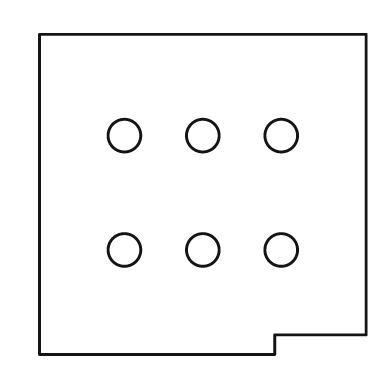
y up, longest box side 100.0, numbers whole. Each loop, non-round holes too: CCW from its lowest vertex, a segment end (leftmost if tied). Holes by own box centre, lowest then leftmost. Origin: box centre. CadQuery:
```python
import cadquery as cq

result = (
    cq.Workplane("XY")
    .moveTo(-50.0, -49.0)
    .lineTo(22.0, -49.0)
    .lineTo(22.0, -43.0)
    .lineTo(50.0, -43.0)
    .lineTo(50.0, 49.0)
    .lineTo(-50.0, 49.0)
    .close()
    .moveTo(-24.0, -17.0)
    .circle(5.0)
    .moveTo(0.0, -17.0)
    .circle(5.0)
    .moveTo(24.0, -17.0)
    .circle(5.0)
    .moveTo(-24.0, 18.0)
    .circle(5.0)
    .moveTo(0.0, 18.0)
    .circle(5.0)
    .moveTo(24.0, 18.0)
    .circle(5.0)
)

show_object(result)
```